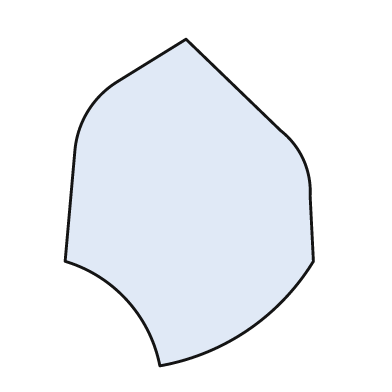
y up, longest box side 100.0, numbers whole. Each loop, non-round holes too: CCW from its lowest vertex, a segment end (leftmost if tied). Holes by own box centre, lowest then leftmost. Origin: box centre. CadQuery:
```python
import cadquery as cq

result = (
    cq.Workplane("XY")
    .moveTo(-9.0, -50.0)
    .threePointArc((18.0, -39.0), (38.0, -18.0))
    .lineTo(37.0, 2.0)
    .threePointArc((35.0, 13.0), (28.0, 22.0))
    .lineTo(-1.0, 50.0)
    .lineTo(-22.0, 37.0)
    .threePointArc((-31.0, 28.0), (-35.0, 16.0))
    .lineTo(-38.0, -18.0)
    .threePointArc((-19.0, -30.0), (-9.0, -50.0))
    .close()
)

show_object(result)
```